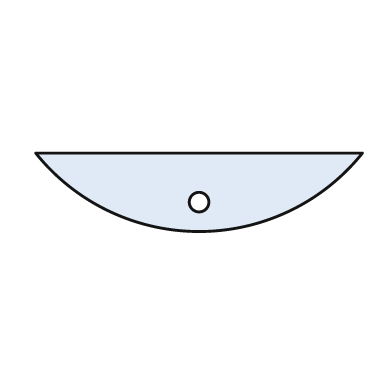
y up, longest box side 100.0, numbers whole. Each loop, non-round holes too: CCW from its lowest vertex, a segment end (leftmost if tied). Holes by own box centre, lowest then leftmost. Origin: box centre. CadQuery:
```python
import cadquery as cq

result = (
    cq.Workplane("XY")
    .moveTo(-50.0, 12.0)
    .threePointArc((0.0, -12.0), (50.0, 12.0))
    .close()
    .moveTo(0.0, -3.0)
    .circle(3.0)
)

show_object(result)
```